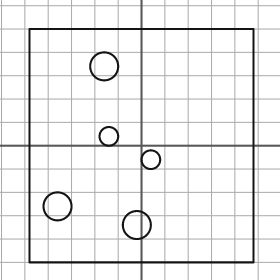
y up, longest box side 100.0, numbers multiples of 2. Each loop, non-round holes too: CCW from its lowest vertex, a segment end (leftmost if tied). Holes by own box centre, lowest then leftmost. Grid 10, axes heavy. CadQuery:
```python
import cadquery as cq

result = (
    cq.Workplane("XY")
    .moveTo(-48.0, -50.0)
    .lineTo(48.0, -50.0)
    .lineTo(48.0, 50.0)
    .lineTo(-48.0, 50.0)
    .close()
    .moveTo(-2.0, -34.0)
    .circle(6.0)
    .moveTo(-36.0, -26.0)
    .circle(6.0)
    .moveTo(4.0, -6.0)
    .circle(4.0)
    .moveTo(-14.0, 4.0)
    .circle(4.0)
    .moveTo(-16.0, 34.0)
    .circle(6.0)
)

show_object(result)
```